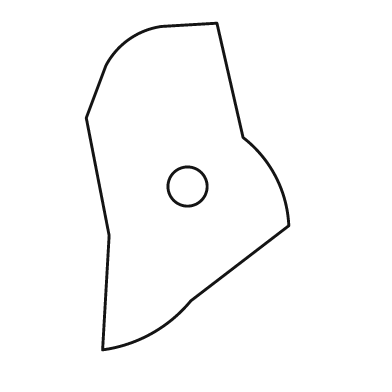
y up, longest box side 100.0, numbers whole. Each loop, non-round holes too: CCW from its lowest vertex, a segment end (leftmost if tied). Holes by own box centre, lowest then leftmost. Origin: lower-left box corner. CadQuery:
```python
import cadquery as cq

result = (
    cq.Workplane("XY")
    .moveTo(5.0, 0.0)
    .threePointArc((20.0, 5.0), (32.0, 15.0))
    .lineTo(62.0, 38.0)
    .threePointArc((58.0, 53.0), (48.0, 65.0))
    .lineTo(40.0, 100.0)
    .lineTo(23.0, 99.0)
    .threePointArc((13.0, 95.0), (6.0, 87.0))
    .lineTo(0.0, 71.0)
    .lineTo(7.0, 35.0)
    .close()
    .moveTo(31.0, 50.0)
    .circle(6.0)
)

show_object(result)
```